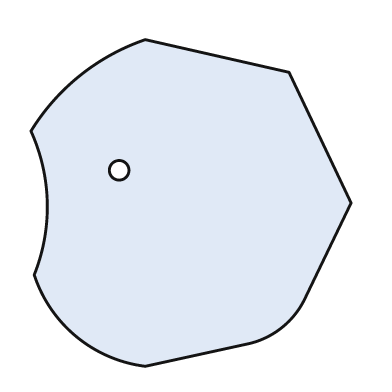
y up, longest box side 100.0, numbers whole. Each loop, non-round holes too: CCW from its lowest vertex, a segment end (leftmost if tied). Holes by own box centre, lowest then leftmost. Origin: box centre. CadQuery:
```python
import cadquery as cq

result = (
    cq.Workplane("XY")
    .moveTo(-14.0, -50.0)
    .lineTo(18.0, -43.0)
    .threePointArc((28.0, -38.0), (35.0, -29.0))
    .lineTo(49.0, 0.0)
    .lineTo(30.0, 40.0)
    .lineTo(-14.0, 50.0)
    .threePointArc((-34.0, 39.0), (-49.0, 22.0))
    .threePointArc((-44.0, 0.0), (-48.0, -22.0))
    .threePointArc((-35.0, -41.0), (-14.0, -50.0))
    .close()
    .moveTo(-22.0, 10.0)
    .circle(3.0)
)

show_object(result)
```